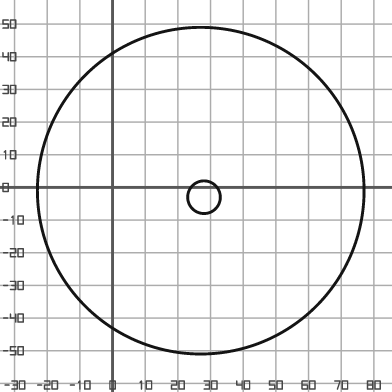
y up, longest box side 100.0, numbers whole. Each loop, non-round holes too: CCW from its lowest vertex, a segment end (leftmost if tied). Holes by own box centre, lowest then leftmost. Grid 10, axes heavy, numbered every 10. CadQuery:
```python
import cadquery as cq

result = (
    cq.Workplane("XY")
    .moveTo(27.0, -1.0)
    .circle(50.0)
    .moveTo(28.0, -3.0)
    .circle(5.0)
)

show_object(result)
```